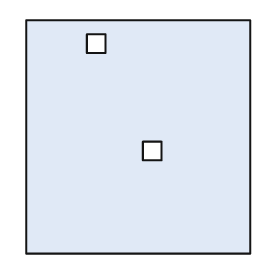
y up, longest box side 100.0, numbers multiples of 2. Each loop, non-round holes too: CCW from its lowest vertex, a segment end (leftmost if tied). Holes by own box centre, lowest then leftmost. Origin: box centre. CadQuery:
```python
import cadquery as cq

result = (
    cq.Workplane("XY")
    .moveTo(-48.0, -50.0)
    .lineTo(48.0, -50.0)
    .lineTo(48.0, 50.0)
    .lineTo(-48.0, 50.0)
    .close()
    .moveTo(2.0, -10.0)
    .lineTo(10.0, -10.0)
    .lineTo(10.0, -2.0)
    .lineTo(2.0, -2.0)
    .close()
    .moveTo(-22.0, 36.0)
    .lineTo(-14.0, 36.0)
    .lineTo(-14.0, 44.0)
    .lineTo(-22.0, 44.0)
    .close()
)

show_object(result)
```